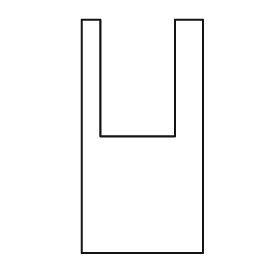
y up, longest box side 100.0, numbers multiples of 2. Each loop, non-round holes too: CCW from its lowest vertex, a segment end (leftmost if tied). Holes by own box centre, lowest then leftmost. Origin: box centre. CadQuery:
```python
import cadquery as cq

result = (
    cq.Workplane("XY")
    .moveTo(-26.0, -50.0)
    .lineTo(26.0, -50.0)
    .lineTo(26.0, 50.0)
    .lineTo(14.0, 50.0)
    .lineTo(14.0, 0.0)
    .lineTo(-18.0, 0.0)
    .lineTo(-18.0, 50.0)
    .lineTo(-26.0, 50.0)
    .close()
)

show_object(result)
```